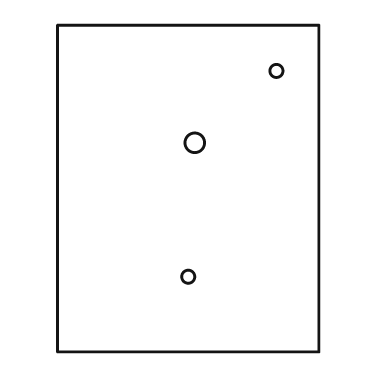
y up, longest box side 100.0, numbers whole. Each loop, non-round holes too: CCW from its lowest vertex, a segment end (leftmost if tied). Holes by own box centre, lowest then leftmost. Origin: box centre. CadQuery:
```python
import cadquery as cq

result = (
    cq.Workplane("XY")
    .moveTo(-40.0, -50.0)
    .lineTo(40.0, -50.0)
    .lineTo(40.0, 50.0)
    .lineTo(-40.0, 50.0)
    .close()
    .moveTo(0.0, -27.0)
    .circle(2.0)
    .moveTo(2.0, 14.0)
    .circle(3.0)
    .moveTo(27.0, 36.0)
    .circle(2.0)
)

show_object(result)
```